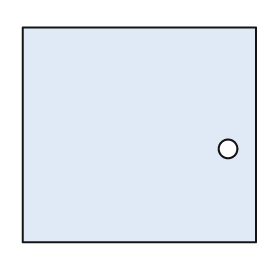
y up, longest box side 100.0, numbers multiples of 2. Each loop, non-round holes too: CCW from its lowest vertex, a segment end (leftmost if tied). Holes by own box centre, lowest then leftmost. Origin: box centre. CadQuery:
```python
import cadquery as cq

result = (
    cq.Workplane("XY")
    .moveTo(-50.0, -46.0)
    .lineTo(50.0, -46.0)
    .lineTo(50.0, 46.0)
    .lineTo(-50.0, 46.0)
    .close()
    .moveTo(38.0, -6.0)
    .circle(4.0)
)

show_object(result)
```